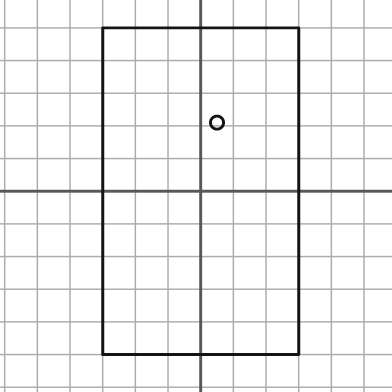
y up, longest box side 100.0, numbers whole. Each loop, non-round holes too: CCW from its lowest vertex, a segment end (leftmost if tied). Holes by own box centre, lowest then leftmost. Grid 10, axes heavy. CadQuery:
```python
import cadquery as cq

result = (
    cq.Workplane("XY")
    .moveTo(-30.0, -50.0)
    .lineTo(30.0, -50.0)
    .lineTo(30.0, 50.0)
    .lineTo(-30.0, 50.0)
    .close()
    .moveTo(5.0, 21.0)
    .circle(2.0)
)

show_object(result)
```